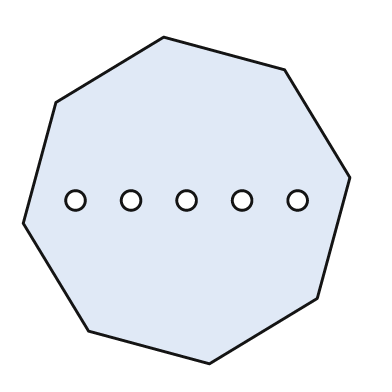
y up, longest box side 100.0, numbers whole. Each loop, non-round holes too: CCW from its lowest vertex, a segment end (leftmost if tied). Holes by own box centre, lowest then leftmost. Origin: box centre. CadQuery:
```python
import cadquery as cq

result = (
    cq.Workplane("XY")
    .moveTo(7.0, -50.0)
    .lineTo(40.0, -30.0)
    .lineTo(50.0, 7.0)
    .lineTo(30.0, 40.0)
    .lineTo(-7.0, 50.0)
    .lineTo(-40.0, 30.0)
    .lineTo(-50.0, -7.0)
    .lineTo(-30.0, -40.0)
    .close()
    .moveTo(-34.0, 0.0)
    .circle(3.0)
    .moveTo(-17.0, 0.0)
    .circle(3.0)
    .moveTo(0.0, 0.0)
    .circle(3.0)
    .moveTo(17.0, 0.0)
    .circle(3.0)
    .moveTo(34.0, 0.0)
    .circle(3.0)
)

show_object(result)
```